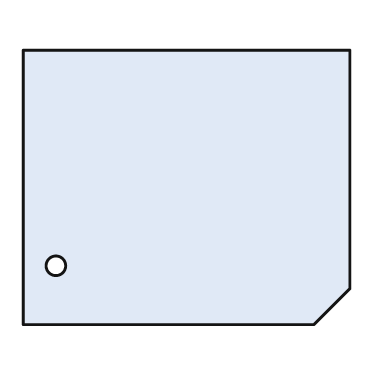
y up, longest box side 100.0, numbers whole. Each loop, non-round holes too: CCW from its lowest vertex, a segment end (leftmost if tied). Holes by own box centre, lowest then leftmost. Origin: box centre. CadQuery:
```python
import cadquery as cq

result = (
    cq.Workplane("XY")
    .moveTo(-50.0, -42.0)
    .lineTo(39.0, -42.0)
    .lineTo(50.0, -31.0)
    .lineTo(50.0, 42.0)
    .lineTo(-50.0, 42.0)
    .close()
    .moveTo(-40.0, -24.0)
    .circle(3.0)
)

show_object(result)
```